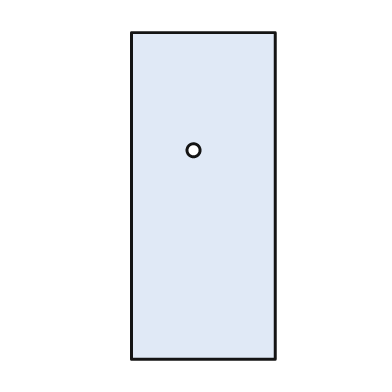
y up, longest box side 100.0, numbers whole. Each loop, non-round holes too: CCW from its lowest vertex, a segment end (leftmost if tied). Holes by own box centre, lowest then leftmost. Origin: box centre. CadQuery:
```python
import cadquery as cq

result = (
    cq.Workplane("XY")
    .moveTo(-22.0, -50.0)
    .lineTo(22.0, -50.0)
    .lineTo(22.0, 50.0)
    .lineTo(-22.0, 50.0)
    .close()
    .moveTo(-3.0, 14.0)
    .circle(2.0)
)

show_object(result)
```